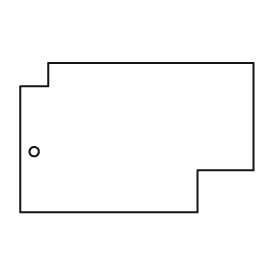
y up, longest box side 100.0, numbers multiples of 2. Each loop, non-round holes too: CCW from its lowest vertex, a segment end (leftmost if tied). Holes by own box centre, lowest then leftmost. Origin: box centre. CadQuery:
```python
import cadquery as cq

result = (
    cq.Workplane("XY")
    .moveTo(-50.0, -32.0)
    .lineTo(26.0, -32.0)
    .lineTo(26.0, -14.0)
    .lineTo(50.0, -14.0)
    .lineTo(50.0, 32.0)
    .lineTo(-38.0, 32.0)
    .lineTo(-38.0, 22.0)
    .lineTo(-50.0, 22.0)
    .close()
    .moveTo(-44.0, -6.0)
    .circle(2.0)
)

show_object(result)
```